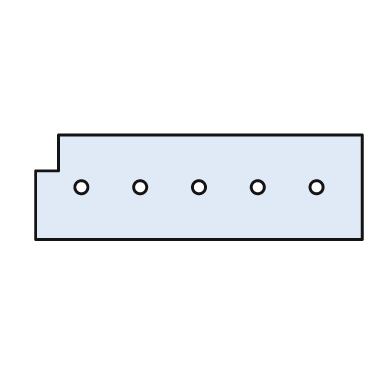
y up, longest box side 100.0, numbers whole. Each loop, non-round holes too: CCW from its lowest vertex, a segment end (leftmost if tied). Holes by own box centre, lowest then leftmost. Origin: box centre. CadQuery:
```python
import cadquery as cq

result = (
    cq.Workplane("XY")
    .moveTo(-50.0, -16.0)
    .lineTo(50.0, -16.0)
    .lineTo(50.0, 16.0)
    .lineTo(-43.0, 16.0)
    .lineTo(-43.0, 5.0)
    .lineTo(-50.0, 5.0)
    .close()
    .moveTo(-36.0, 0.0)
    .circle(2.0)
    .moveTo(-18.0, 0.0)
    .circle(2.0)
    .moveTo(0.0, 0.0)
    .circle(2.0)
    .moveTo(18.0, 0.0)
    .circle(2.0)
    .moveTo(36.0, 0.0)
    .circle(2.0)
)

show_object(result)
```